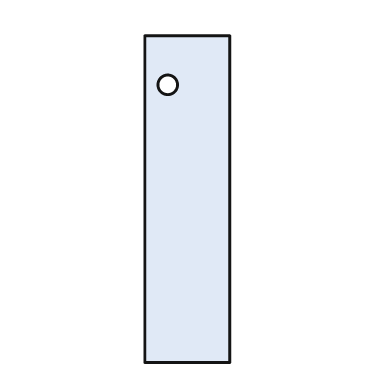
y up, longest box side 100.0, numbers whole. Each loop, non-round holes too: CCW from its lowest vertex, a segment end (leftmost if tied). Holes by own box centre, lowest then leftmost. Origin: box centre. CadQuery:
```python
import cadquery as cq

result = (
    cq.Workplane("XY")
    .moveTo(-13.0, -50.0)
    .lineTo(13.0, -50.0)
    .lineTo(13.0, 50.0)
    .lineTo(-13.0, 50.0)
    .close()
    .moveTo(-6.0, 35.0)
    .circle(3.0)
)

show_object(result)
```